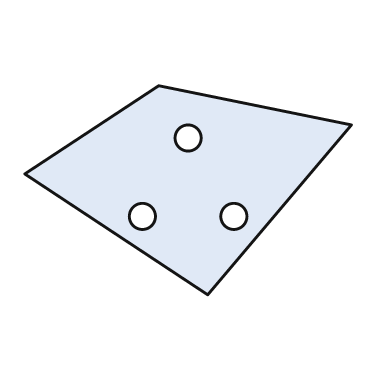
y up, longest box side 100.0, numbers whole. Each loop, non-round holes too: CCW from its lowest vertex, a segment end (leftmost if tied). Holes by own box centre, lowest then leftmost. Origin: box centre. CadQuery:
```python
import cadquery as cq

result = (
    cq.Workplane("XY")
    .moveTo(6.0, -32.0)
    .lineTo(50.0, 20.0)
    .lineTo(-9.0, 32.0)
    .lineTo(-50.0, 5.0)
    .close()
    .moveTo(-14.0, -8.0)
    .circle(4.0)
    .moveTo(14.0, -8.0)
    .circle(4.0)
    .moveTo(0.0, 16.0)
    .circle(4.0)
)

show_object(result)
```